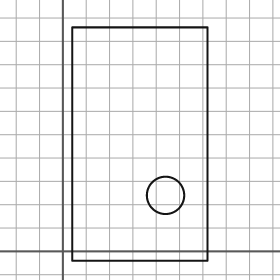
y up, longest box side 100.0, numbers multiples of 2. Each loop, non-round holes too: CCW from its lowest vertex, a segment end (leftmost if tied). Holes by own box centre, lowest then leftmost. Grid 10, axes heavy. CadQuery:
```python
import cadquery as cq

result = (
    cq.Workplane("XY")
    .moveTo(4.0, -4.0)
    .lineTo(62.0, -4.0)
    .lineTo(62.0, 96.0)
    .lineTo(4.0, 96.0)
    .close()
    .moveTo(44.0, 24.0)
    .circle(8.0)
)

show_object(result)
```